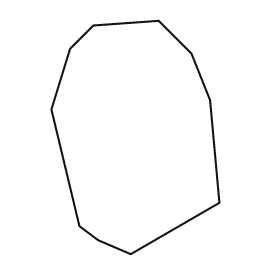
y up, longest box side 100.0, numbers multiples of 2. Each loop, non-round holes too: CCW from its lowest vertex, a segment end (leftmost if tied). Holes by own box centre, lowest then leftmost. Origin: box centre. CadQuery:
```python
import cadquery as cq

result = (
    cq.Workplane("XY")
    .moveTo(-2.0, -50.0)
    .lineTo(36.0, -28.0)
    .lineTo(32.0, 16.0)
    .lineTo(24.0, 36.0)
    .lineTo(10.0, 50.0)
    .lineTo(-18.0, 48.0)
    .lineTo(-28.0, 38.0)
    .lineTo(-36.0, 12.0)
    .lineTo(-24.0, -38.0)
    .lineTo(-16.0, -44.0)
    .close()
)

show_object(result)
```